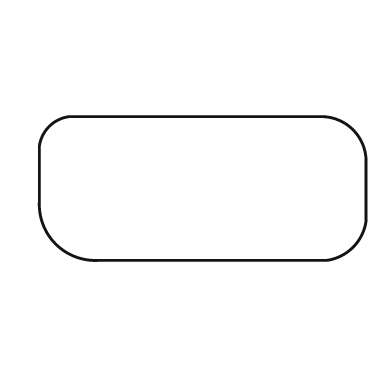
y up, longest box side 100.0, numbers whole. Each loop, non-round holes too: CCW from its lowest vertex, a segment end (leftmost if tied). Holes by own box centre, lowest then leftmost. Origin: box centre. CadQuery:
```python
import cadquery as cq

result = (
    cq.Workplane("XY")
    .moveTo(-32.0, -22.0)
    .lineTo(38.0, -22.0)
    .threePointArc((46.0, -18.0), (50.0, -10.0))
    .lineTo(50.0, 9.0)
    .threePointArc((46.0, 18.0), (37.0, 22.0))
    .lineTo(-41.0, 22.0)
    .threePointArc((-47.0, 19.0), (-50.0, 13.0))
    .lineTo(-50.0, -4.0)
    .threePointArc((-45.0, -17.0), (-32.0, -22.0))
    .close()
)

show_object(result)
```